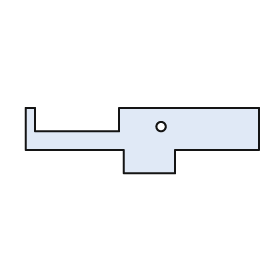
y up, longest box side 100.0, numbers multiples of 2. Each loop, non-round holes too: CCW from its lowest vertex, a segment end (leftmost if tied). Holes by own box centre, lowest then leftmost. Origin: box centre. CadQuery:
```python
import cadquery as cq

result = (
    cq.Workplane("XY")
    .moveTo(-8.0, -14.0)
    .lineTo(14.0, -14.0)
    .lineTo(14.0, -4.0)
    .lineTo(50.0, -4.0)
    .lineTo(50.0, 14.0)
    .lineTo(-10.0, 14.0)
    .lineTo(-10.0, 4.0)
    .lineTo(-46.0, 4.0)
    .lineTo(-46.0, 14.0)
    .lineTo(-50.0, 14.0)
    .lineTo(-50.0, -4.0)
    .lineTo(-8.0, -4.0)
    .close()
    .moveTo(8.0, 6.0)
    .circle(2.0)
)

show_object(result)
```